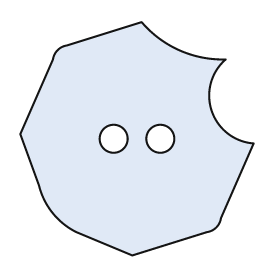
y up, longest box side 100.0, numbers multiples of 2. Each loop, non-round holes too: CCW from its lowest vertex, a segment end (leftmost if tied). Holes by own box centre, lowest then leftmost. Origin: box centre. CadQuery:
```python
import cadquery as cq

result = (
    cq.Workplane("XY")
    .moveTo(-2.0, -50.0)
    .lineTo(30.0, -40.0)
    .threePointArc((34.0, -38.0), (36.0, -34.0))
    .lineTo(50.0, -2.0)
    .threePointArc((32.0, 12.0), (38.0, 34.0))
    .threePointArc((18.0, 38.0), (2.0, 50.0))
    .lineTo(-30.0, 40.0)
    .threePointArc((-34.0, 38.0), (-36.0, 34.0))
    .lineTo(-50.0, 2.0)
    .lineTo(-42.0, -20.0)
    .threePointArc((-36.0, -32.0), (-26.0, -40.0))
    .close()
    .moveTo(-10.0, 0.0)
    .circle(6.0)
    .moveTo(10.0, 0.0)
    .circle(6.0)
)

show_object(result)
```